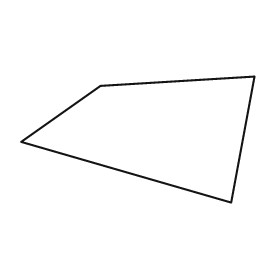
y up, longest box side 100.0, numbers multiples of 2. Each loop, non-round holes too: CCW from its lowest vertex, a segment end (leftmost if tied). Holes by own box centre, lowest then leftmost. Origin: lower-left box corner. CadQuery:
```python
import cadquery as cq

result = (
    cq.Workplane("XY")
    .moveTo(90.0, 0.0)
    .lineTo(100.0, 54.0)
    .lineTo(34.0, 50.0)
    .lineTo(0.0, 26.0)
    .close()
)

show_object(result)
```